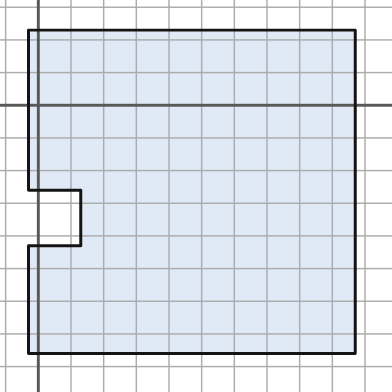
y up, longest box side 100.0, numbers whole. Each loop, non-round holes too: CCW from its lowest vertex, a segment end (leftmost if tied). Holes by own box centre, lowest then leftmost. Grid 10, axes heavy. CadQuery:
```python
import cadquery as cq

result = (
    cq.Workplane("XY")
    .moveTo(-3.0, -76.0)
    .lineTo(97.0, -76.0)
    .lineTo(97.0, 23.0)
    .lineTo(-3.0, 23.0)
    .lineTo(-3.0, -26.0)
    .lineTo(13.0, -26.0)
    .lineTo(13.0, -43.0)
    .lineTo(-3.0, -43.0)
    .close()
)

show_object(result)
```